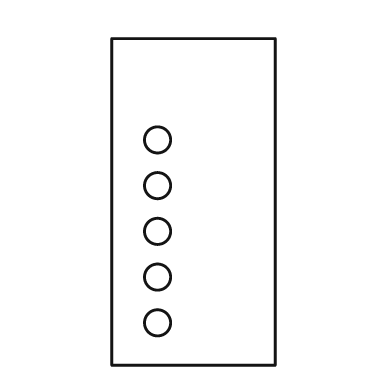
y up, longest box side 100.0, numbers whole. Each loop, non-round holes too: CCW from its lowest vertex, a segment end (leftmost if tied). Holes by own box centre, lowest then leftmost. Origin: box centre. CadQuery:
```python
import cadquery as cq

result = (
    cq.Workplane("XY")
    .moveTo(-25.0, -50.0)
    .lineTo(25.0, -50.0)
    .lineTo(25.0, 50.0)
    .lineTo(-25.0, 50.0)
    .close()
    .moveTo(-11.0, -37.0)
    .circle(4.0)
    .moveTo(-11.0, -23.0)
    .circle(4.0)
    .moveTo(-11.0, -9.0)
    .circle(4.0)
    .moveTo(-11.0, 5.0)
    .circle(4.0)
    .moveTo(-11.0, 19.0)
    .circle(4.0)
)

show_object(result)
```